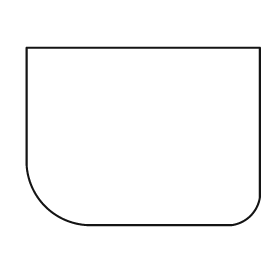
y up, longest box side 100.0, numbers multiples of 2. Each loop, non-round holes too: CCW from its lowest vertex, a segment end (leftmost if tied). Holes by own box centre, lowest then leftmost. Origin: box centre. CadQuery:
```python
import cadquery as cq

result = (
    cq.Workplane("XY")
    .moveTo(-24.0, -38.0)
    .lineTo(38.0, -38.0)
    .threePointArc((46.0, -34.0), (50.0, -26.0))
    .lineTo(50.0, 38.0)
    .lineTo(-50.0, 38.0)
    .lineTo(-50.0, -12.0)
    .threePointArc((-42.0, -30.0), (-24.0, -38.0))
    .close()
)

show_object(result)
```